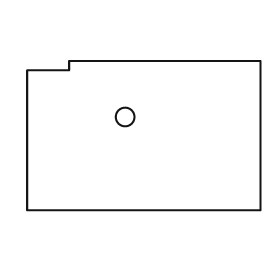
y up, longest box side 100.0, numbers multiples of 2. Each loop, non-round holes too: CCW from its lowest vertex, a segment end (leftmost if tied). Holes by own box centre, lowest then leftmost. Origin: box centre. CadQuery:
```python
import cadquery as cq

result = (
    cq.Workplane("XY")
    .moveTo(-50.0, -32.0)
    .lineTo(50.0, -32.0)
    .lineTo(50.0, 32.0)
    .lineTo(-32.0, 32.0)
    .lineTo(-32.0, 28.0)
    .lineTo(-50.0, 28.0)
    .close()
    .moveTo(-8.0, 8.0)
    .circle(4.0)
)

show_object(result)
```